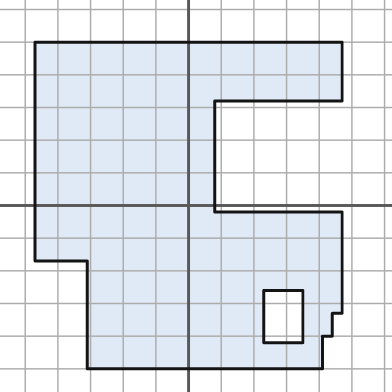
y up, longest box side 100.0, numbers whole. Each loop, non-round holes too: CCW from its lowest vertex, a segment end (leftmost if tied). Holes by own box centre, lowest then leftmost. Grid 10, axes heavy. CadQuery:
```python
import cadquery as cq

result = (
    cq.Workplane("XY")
    .moveTo(-31.0, -50.0)
    .lineTo(41.0, -50.0)
    .lineTo(41.0, -40.0)
    .lineTo(44.0, -40.0)
    .lineTo(44.0, -33.0)
    .lineTo(47.0, -33.0)
    .lineTo(47.0, -2.0)
    .lineTo(8.0, -2.0)
    .lineTo(8.0, 32.0)
    .lineTo(47.0, 32.0)
    .lineTo(47.0, 50.0)
    .lineTo(-47.0, 50.0)
    .lineTo(-47.0, -17.0)
    .lineTo(-31.0, -17.0)
    .close()
    .moveTo(23.0, -42.0)
    .lineTo(35.0, -42.0)
    .lineTo(35.0, -26.0)
    .lineTo(23.0, -26.0)
    .close()
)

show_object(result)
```